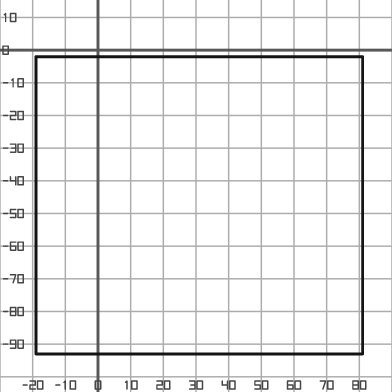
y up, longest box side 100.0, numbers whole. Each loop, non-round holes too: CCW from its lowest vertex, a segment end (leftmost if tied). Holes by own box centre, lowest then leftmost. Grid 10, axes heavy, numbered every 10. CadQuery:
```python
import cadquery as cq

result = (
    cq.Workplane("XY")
    .moveTo(-19.0, -93.0)
    .lineTo(81.0, -93.0)
    .lineTo(81.0, -2.0)
    .lineTo(-19.0, -2.0)
    .close()
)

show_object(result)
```